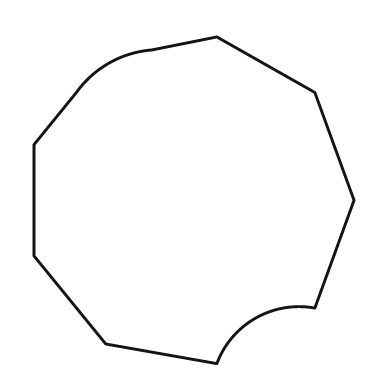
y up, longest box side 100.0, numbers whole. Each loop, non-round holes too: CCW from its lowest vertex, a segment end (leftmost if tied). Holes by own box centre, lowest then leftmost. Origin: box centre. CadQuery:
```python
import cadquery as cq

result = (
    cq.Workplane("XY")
    .moveTo(7.0, -50.0)
    .threePointArc((19.0, -36.0), (37.0, -33.0))
    .lineTo(49.0, 0.0)
    .lineTo(37.0, 33.0)
    .lineTo(7.0, 50.0)
    .lineTo(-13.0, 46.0)
    .threePointArc((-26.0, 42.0), (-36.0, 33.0))
    .lineTo(-49.0, 17.0)
    .lineTo(-49.0, -17.0)
    .lineTo(-27.0, -44.0)
    .close()
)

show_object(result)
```